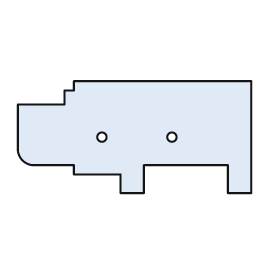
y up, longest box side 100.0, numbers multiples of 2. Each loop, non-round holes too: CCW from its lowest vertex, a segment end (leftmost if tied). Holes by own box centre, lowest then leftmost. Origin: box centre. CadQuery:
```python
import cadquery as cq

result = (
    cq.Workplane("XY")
    .moveTo(-6.0, -24.0)
    .lineTo(4.0, -24.0)
    .lineTo(4.0, -12.0)
    .lineTo(40.0, -12.0)
    .lineTo(40.0, -24.0)
    .lineTo(50.0, -24.0)
    .lineTo(50.0, 24.0)
    .lineTo(-26.0, 24.0)
    .lineTo(-26.0, 20.0)
    .lineTo(-30.0, 20.0)
    .lineTo(-30.0, 14.0)
    .lineTo(-50.0, 14.0)
    .lineTo(-50.0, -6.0)
    .threePointArc((-48.0, -10.0), (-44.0, -12.0))
    .lineTo(-26.0, -12.0)
    .lineTo(-26.0, -16.0)
    .lineTo(-6.0, -16.0)
    .close()
    .moveTo(-14.0, 0.0)
    .circle(2.0)
    .moveTo(16.0, 0.0)
    .circle(2.0)
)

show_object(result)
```